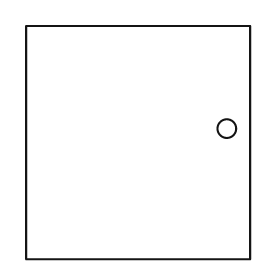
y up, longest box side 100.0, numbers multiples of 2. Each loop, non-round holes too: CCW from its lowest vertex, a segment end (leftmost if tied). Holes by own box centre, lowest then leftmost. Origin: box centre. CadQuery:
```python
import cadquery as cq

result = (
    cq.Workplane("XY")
    .moveTo(-48.0, -50.0)
    .lineTo(48.0, -50.0)
    .lineTo(48.0, 50.0)
    .lineTo(-48.0, 50.0)
    .close()
    .moveTo(38.0, 6.0)
    .circle(4.0)
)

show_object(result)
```